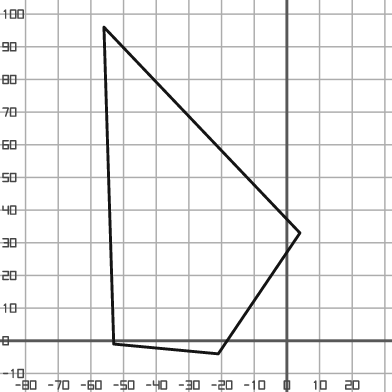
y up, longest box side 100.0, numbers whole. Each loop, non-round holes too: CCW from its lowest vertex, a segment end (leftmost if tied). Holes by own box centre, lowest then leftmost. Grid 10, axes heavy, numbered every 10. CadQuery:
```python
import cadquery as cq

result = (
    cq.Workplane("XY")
    .moveTo(-21.0, -4.0)
    .lineTo(4.0, 33.0)
    .lineTo(-56.0, 96.0)
    .lineTo(-53.0, -1.0)
    .close()
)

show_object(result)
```